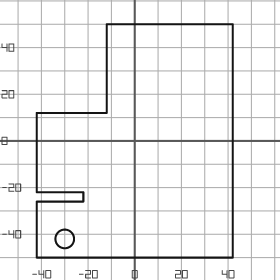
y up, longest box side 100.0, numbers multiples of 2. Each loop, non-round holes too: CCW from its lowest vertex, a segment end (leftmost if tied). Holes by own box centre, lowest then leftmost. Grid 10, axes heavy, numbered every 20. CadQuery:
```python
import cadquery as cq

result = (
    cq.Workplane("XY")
    .moveTo(-42.0, -50.0)
    .lineTo(42.0, -50.0)
    .lineTo(42.0, 50.0)
    .lineTo(-12.0, 50.0)
    .lineTo(-12.0, 12.0)
    .lineTo(-42.0, 12.0)
    .lineTo(-42.0, -22.0)
    .lineTo(-22.0, -22.0)
    .lineTo(-22.0, -26.0)
    .lineTo(-42.0, -26.0)
    .close()
    .moveTo(-30.0, -42.0)
    .circle(4.0)
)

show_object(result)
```